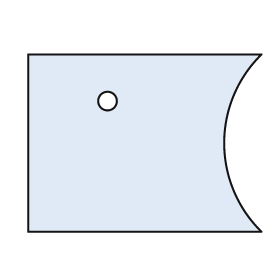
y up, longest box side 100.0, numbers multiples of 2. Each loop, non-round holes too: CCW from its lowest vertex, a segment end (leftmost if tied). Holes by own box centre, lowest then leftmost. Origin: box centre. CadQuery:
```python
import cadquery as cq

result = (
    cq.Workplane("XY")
    .moveTo(-50.0, -38.0)
    .lineTo(50.0, -38.0)
    .threePointArc((34.0, 0.0), (50.0, 38.0))
    .lineTo(-50.0, 38.0)
    .close()
    .moveTo(-16.0, 18.0)
    .circle(4.0)
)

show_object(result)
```